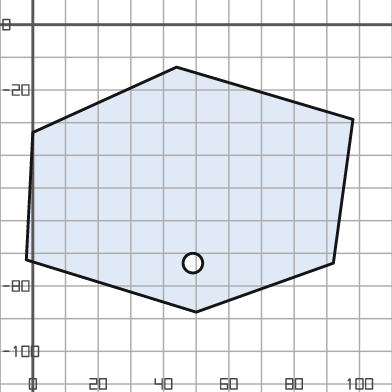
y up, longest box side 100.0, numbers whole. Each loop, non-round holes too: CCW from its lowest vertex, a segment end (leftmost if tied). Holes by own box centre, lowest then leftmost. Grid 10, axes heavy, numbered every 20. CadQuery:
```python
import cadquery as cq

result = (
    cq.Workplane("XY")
    .moveTo(50.0, -88.0)
    .lineTo(92.0, -73.0)
    .lineTo(98.0, -29.0)
    .lineTo(44.0, -13.0)
    .lineTo(0.0, -33.0)
    .lineTo(-2.0, -72.0)
    .close()
    .moveTo(49.0, -73.0)
    .circle(3.0)
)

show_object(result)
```